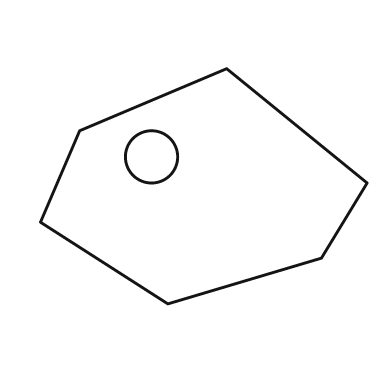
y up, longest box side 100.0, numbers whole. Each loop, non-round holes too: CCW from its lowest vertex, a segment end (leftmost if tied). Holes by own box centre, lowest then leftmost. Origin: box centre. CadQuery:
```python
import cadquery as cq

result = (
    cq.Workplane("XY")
    .moveTo(-11.0, -36.0)
    .lineTo(36.0, -22.0)
    .lineTo(50.0, 1.0)
    .lineTo(7.0, 36.0)
    .lineTo(-38.0, 17.0)
    .lineTo(-50.0, -11.0)
    .close()
    .moveTo(-16.0, 9.0)
    .circle(8.0)
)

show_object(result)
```